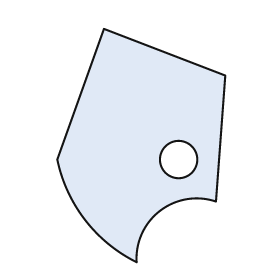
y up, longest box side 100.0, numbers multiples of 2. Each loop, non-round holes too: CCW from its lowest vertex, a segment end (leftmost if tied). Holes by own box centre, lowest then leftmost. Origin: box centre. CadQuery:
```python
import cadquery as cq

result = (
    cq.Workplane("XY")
    .moveTo(-2.0, -50.0)
    .threePointArc((8.0, -28.0), (32.0, -24.0))
    .lineTo(36.0, 30.0)
    .lineTo(-16.0, 50.0)
    .lineTo(-36.0, -6.0)
    .threePointArc((-24.0, -32.0), (-2.0, -50.0))
    .close()
    .moveTo(16.0, -6.0)
    .circle(8.0)
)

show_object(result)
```